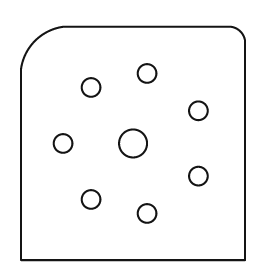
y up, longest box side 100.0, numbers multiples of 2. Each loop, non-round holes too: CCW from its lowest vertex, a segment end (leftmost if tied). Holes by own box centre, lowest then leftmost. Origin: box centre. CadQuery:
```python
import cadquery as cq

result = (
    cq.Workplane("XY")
    .moveTo(-48.0, -50.0)
    .lineTo(48.0, -50.0)
    .lineTo(48.0, 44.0)
    .threePointArc((46.0, 48.0), (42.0, 50.0))
    .lineTo(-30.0, 50.0)
    .threePointArc((-42.0, 44.0), (-48.0, 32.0))
    .close()
    .moveTo(6.0, -30.0)
    .circle(4.0)
    .moveTo(-18.0, -24.0)
    .circle(4.0)
    .moveTo(28.0, -14.0)
    .circle(4.0)
    .moveTo(-30.0, 0.0)
    .circle(4.0)
    .moveTo(0.0, 0.0)
    .circle(6.0)
    .moveTo(28.0, 14.0)
    .circle(4.0)
    .moveTo(-18.0, 24.0)
    .circle(4.0)
    .moveTo(6.0, 30.0)
    .circle(4.0)
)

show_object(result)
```